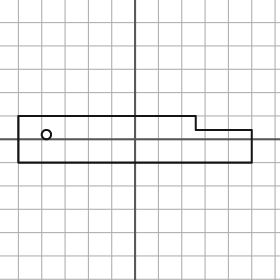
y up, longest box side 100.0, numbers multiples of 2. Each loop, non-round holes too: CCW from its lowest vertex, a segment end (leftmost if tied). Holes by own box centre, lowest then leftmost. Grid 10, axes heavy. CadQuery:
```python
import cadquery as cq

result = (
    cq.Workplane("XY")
    .moveTo(-50.0, -10.0)
    .lineTo(50.0, -10.0)
    .lineTo(50.0, 4.0)
    .lineTo(26.0, 4.0)
    .lineTo(26.0, 10.0)
    .lineTo(-50.0, 10.0)
    .close()
    .moveTo(-38.0, 2.0)
    .circle(2.0)
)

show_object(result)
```